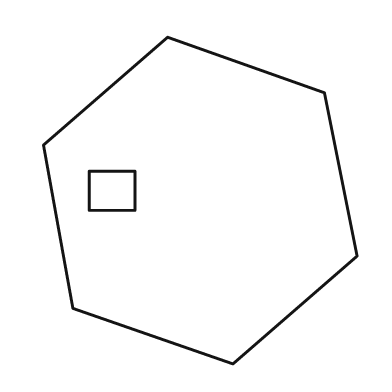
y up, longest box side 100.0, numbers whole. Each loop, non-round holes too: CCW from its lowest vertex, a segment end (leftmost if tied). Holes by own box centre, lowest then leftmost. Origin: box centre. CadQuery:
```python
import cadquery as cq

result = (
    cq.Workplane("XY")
    .moveTo(10.0, -50.0)
    .lineTo(48.0, -17.0)
    .lineTo(38.0, 33.0)
    .lineTo(-10.0, 50.0)
    .lineTo(-48.0, 17.0)
    .lineTo(-39.0, -33.0)
    .close()
    .moveTo(-34.0, -3.0)
    .lineTo(-20.0, -3.0)
    .lineTo(-20.0, 9.0)
    .lineTo(-34.0, 9.0)
    .close()
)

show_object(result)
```